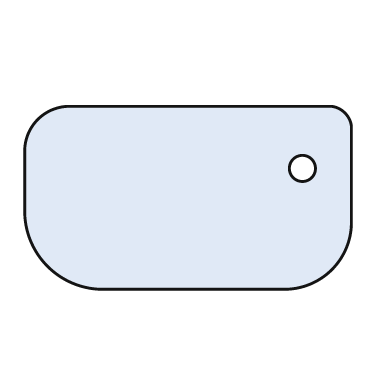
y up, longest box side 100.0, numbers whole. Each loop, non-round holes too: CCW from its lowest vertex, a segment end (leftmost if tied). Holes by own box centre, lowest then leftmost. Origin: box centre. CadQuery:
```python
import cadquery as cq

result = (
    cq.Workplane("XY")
    .moveTo(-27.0, -28.0)
    .lineTo(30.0, -28.0)
    .threePointArc((44.0, -22.0), (50.0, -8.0))
    .lineTo(50.0, 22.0)
    .threePointArc((48.0, 26.0), (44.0, 28.0))
    .lineTo(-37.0, 28.0)
    .threePointArc((-46.0, 24.0), (-50.0, 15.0))
    .lineTo(-50.0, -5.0)
    .threePointArc((-43.0, -21.0), (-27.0, -28.0))
    .close()
    .moveTo(35.0, 9.0)
    .circle(4.0)
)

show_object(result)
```